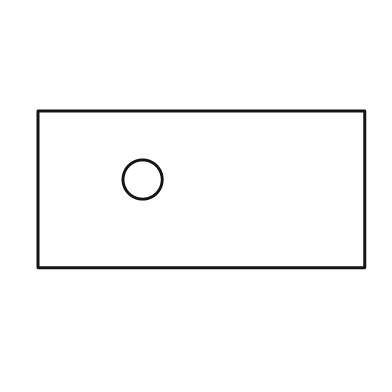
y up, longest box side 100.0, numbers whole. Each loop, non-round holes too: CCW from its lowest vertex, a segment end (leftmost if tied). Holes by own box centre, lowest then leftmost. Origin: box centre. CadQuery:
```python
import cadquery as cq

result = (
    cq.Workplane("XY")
    .moveTo(-50.0, -24.0)
    .lineTo(50.0, -24.0)
    .lineTo(50.0, 24.0)
    .lineTo(-50.0, 24.0)
    .close()
    .moveTo(-18.0, 3.0)
    .circle(6.0)
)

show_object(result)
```